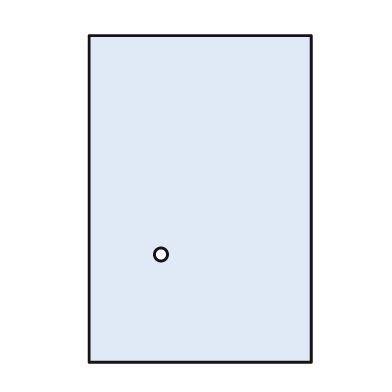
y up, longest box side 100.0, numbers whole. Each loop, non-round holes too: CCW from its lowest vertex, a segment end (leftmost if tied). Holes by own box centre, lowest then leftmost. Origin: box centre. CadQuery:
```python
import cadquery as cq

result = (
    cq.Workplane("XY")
    .moveTo(-34.0, -50.0)
    .lineTo(34.0, -50.0)
    .lineTo(34.0, 50.0)
    .lineTo(-34.0, 50.0)
    .close()
    .moveTo(-12.0, -17.0)
    .circle(2.0)
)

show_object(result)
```